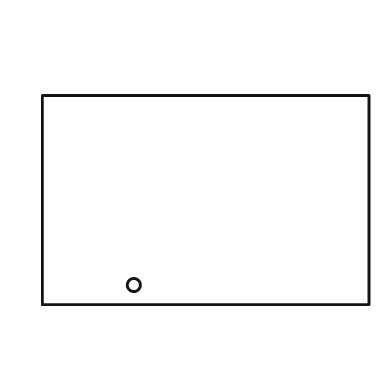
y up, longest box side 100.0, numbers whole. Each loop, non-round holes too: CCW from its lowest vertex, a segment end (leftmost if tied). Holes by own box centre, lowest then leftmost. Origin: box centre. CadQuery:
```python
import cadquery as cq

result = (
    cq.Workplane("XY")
    .moveTo(-50.0, -32.0)
    .lineTo(50.0, -32.0)
    .lineTo(50.0, 32.0)
    .lineTo(-50.0, 32.0)
    .close()
    .moveTo(-22.0, -26.0)
    .circle(2.0)
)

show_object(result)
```